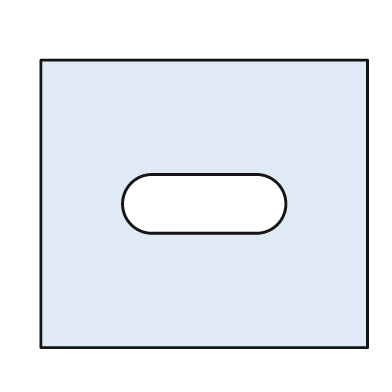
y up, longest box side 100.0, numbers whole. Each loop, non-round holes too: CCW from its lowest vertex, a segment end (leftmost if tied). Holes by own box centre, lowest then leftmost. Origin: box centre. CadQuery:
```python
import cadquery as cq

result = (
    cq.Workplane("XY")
    .moveTo(-50.0, -44.0)
    .lineTo(50.0, -44.0)
    .lineTo(50.0, 44.0)
    .lineTo(-50.0, 44.0)
    .close()
    .moveTo(-16.0, -9.0)
    .lineTo(16.0, -9.0)
    .threePointArc((25.0, 0.0), (16.0, 9.0))
    .lineTo(-16.0, 9.0)
    .threePointArc((-25.0, 0.0), (-16.0, -9.0))
    .close()
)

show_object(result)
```